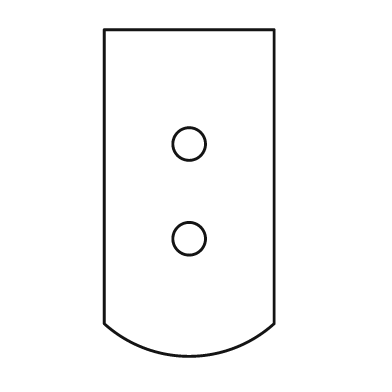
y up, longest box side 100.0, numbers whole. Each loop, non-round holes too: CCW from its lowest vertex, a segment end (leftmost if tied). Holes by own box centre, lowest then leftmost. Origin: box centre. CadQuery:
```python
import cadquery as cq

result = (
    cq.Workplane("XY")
    .moveTo(-26.0, -40.0)
    .threePointArc((0.0, -50.0), (26.0, -40.0))
    .lineTo(26.0, 50.0)
    .lineTo(-26.0, 50.0)
    .close()
    .moveTo(0.0, -14.0)
    .circle(5.0)
    .moveTo(0.0, 15.0)
    .circle(5.0)
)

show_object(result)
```